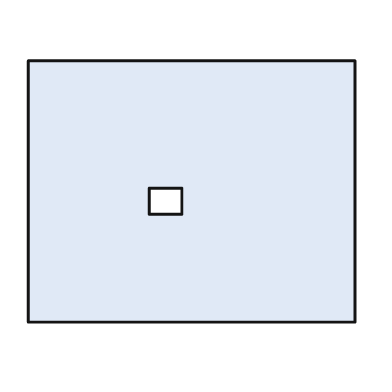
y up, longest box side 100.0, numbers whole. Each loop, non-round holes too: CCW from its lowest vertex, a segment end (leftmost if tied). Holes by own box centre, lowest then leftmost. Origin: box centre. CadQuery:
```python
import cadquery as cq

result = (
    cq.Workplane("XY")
    .moveTo(-50.0, -40.0)
    .lineTo(50.0, -40.0)
    .lineTo(50.0, 40.0)
    .lineTo(-50.0, 40.0)
    .close()
    .moveTo(-13.0, -7.0)
    .lineTo(-3.0, -7.0)
    .lineTo(-3.0, 1.0)
    .lineTo(-13.0, 1.0)
    .close()
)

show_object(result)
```